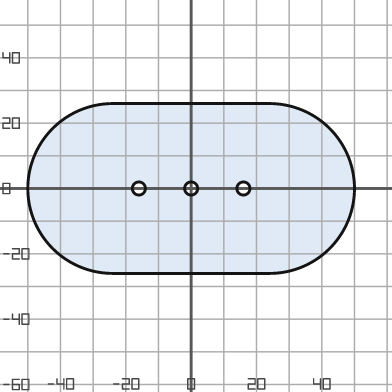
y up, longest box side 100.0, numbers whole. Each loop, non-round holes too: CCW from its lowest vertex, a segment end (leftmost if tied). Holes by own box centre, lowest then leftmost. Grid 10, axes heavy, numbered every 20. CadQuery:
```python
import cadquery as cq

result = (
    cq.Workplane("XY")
    .moveTo(-24.0, -26.0)
    .lineTo(24.0, -26.0)
    .threePointArc((50.0, 0.0), (24.0, 26.0))
    .lineTo(-24.0, 26.0)
    .threePointArc((-50.0, 0.0), (-24.0, -26.0))
    .close()
    .moveTo(-16.0, 0.0)
    .circle(2.0)
    .moveTo(0.0, 0.0)
    .circle(2.0)
    .moveTo(16.0, 0.0)
    .circle(2.0)
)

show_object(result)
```